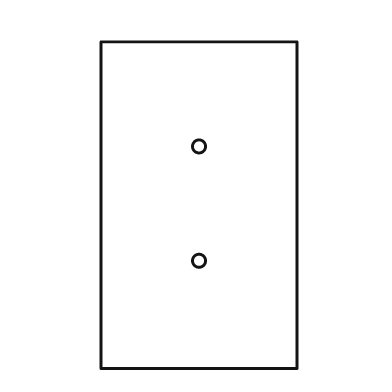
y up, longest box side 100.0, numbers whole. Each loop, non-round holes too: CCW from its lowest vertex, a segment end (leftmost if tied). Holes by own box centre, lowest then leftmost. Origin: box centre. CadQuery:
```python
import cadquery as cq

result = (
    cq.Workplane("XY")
    .moveTo(-30.0, -50.0)
    .lineTo(30.0, -50.0)
    .lineTo(30.0, 50.0)
    .lineTo(-30.0, 50.0)
    .close()
    .moveTo(0.0, -17.0)
    .circle(2.0)
    .moveTo(0.0, 18.0)
    .circle(2.0)
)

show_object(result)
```